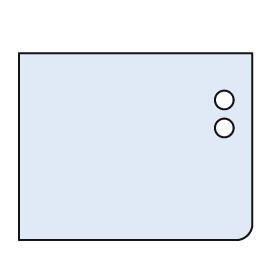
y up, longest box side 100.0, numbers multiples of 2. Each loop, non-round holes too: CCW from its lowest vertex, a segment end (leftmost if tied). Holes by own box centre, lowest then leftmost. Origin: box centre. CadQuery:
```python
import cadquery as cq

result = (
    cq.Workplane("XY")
    .moveTo(-50.0, -40.0)
    .lineTo(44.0, -40.0)
    .threePointArc((48.0, -38.0), (50.0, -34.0))
    .lineTo(50.0, 40.0)
    .lineTo(-50.0, 40.0)
    .close()
    .moveTo(38.0, 8.0)
    .circle(4.0)
    .moveTo(38.0, 20.0)
    .circle(4.0)
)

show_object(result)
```